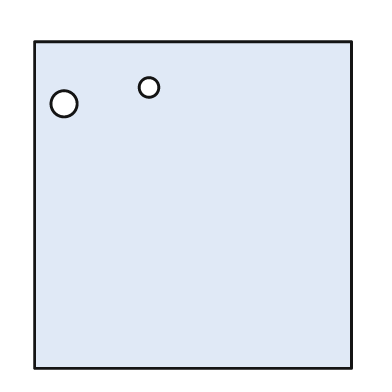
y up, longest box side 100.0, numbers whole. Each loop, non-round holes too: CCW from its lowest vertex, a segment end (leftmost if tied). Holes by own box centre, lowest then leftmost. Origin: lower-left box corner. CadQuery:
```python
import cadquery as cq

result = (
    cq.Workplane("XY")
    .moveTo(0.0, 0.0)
    .lineTo(97.0, 0.0)
    .lineTo(97.0, 100.0)
    .lineTo(0.0, 100.0)
    .close()
    .moveTo(9.0, 81.0)
    .circle(4.0)
    .moveTo(35.0, 86.0)
    .circle(3.0)
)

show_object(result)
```